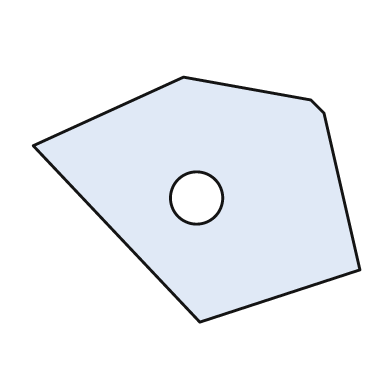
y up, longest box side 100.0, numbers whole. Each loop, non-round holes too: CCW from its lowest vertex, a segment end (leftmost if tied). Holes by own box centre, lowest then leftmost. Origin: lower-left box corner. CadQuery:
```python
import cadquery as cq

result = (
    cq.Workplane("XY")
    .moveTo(51.0, 0.0)
    .lineTo(100.0, 16.0)
    .lineTo(89.0, 64.0)
    .lineTo(85.0, 68.0)
    .lineTo(46.0, 75.0)
    .lineTo(0.0, 54.0)
    .close()
    .moveTo(50.0, 38.0)
    .circle(8.0)
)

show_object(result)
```